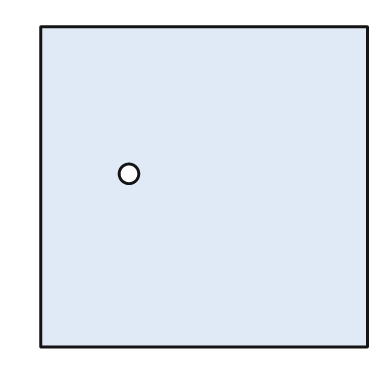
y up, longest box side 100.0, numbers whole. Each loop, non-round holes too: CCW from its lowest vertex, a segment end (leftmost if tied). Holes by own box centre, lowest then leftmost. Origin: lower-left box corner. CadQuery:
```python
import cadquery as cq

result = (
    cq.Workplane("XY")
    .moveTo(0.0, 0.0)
    .lineTo(100.0, 0.0)
    .lineTo(100.0, 98.0)
    .lineTo(0.0, 98.0)
    .close()
    .moveTo(27.0, 53.0)
    .circle(3.0)
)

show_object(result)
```